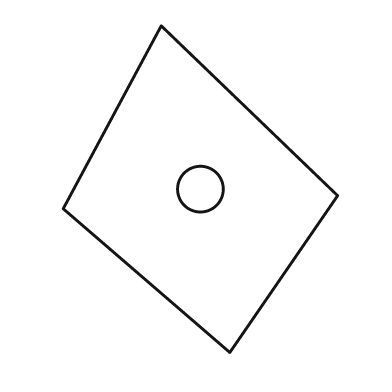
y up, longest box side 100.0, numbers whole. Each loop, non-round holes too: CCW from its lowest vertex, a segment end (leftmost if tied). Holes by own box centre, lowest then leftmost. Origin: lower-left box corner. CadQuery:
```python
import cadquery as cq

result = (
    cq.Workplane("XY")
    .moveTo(51.0, 0.0)
    .lineTo(84.0, 48.0)
    .lineTo(30.0, 100.0)
    .lineTo(0.0, 44.0)
    .close()
    .moveTo(42.0, 50.0)
    .circle(7.0)
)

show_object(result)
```